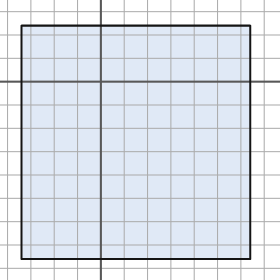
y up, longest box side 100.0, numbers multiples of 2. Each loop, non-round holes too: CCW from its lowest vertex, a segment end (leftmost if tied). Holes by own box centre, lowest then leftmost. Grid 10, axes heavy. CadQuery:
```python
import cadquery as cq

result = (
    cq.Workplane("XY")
    .moveTo(-34.0, -76.0)
    .lineTo(64.0, -76.0)
    .lineTo(64.0, 24.0)
    .lineTo(-34.0, 24.0)
    .close()
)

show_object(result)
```